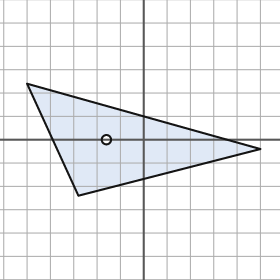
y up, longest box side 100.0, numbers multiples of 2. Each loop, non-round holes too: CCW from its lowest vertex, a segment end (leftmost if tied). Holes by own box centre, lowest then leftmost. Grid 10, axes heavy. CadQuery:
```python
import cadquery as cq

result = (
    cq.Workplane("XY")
    .moveTo(-28.0, -24.0)
    .lineTo(50.0, -4.0)
    .lineTo(-50.0, 24.0)
    .close()
    .moveTo(-16.0, 0.0)
    .circle(2.0)
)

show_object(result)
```